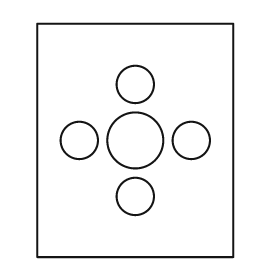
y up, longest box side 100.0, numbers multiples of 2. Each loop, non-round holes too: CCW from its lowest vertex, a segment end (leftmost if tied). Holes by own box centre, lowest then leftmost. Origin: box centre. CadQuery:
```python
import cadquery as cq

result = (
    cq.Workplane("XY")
    .moveTo(-42.0, -50.0)
    .lineTo(42.0, -50.0)
    .lineTo(42.0, 50.0)
    .lineTo(-42.0, 50.0)
    .close()
    .moveTo(0.0, -24.0)
    .circle(8.0)
    .moveTo(-24.0, 0.0)
    .circle(8.0)
    .moveTo(0.0, 0.0)
    .circle(12.0)
    .moveTo(24.0, 0.0)
    .circle(8.0)
    .moveTo(0.0, 24.0)
    .circle(8.0)
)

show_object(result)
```